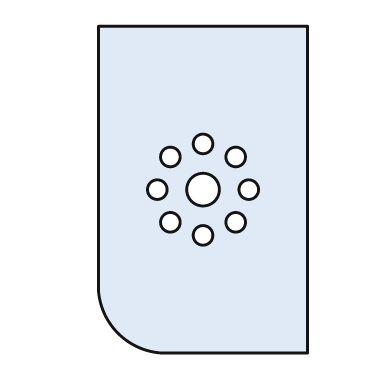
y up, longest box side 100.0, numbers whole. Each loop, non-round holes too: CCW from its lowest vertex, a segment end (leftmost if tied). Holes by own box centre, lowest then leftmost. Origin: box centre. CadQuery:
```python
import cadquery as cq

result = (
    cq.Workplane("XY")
    .moveTo(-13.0, -50.0)
    .lineTo(32.0, -50.0)
    .lineTo(32.0, 50.0)
    .lineTo(-32.0, 50.0)
    .lineTo(-32.0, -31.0)
    .threePointArc((-26.0, -44.0), (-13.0, -50.0))
    .close()
    .moveTo(0.0, -14.0)
    .circle(3.0)
    .moveTo(-10.0, -10.0)
    .circle(3.0)
    .moveTo(10.0, -10.0)
    .circle(3.0)
    .moveTo(-14.0, 0.0)
    .circle(3.0)
    .moveTo(0.0, 0.0)
    .circle(5.0)
    .moveTo(14.0, 0.0)
    .circle(3.0)
    .moveTo(-10.0, 10.0)
    .circle(3.0)
    .moveTo(10.0, 10.0)
    .circle(3.0)
    .moveTo(0.0, 14.0)
    .circle(3.0)
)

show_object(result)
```